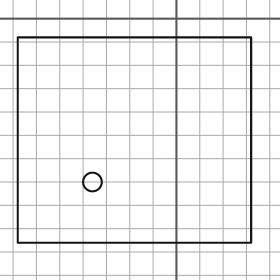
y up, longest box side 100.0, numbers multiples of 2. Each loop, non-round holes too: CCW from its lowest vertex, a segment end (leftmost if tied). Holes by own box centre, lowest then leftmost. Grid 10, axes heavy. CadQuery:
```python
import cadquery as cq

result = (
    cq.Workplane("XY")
    .moveTo(-68.0, -96.0)
    .lineTo(32.0, -96.0)
    .lineTo(32.0, -8.0)
    .lineTo(-68.0, -8.0)
    .close()
    .moveTo(-36.0, -70.0)
    .circle(4.0)
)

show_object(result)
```